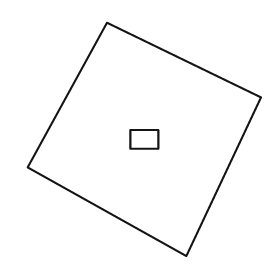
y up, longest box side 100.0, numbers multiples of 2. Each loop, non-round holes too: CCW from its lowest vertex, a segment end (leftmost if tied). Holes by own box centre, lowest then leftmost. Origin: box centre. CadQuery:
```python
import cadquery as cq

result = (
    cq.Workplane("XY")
    .moveTo(18.0, -50.0)
    .lineTo(50.0, 18.0)
    .lineTo(-16.0, 50.0)
    .lineTo(-50.0, -12.0)
    .close()
    .moveTo(-6.0, -4.0)
    .lineTo(6.0, -4.0)
    .lineTo(6.0, 4.0)
    .lineTo(-6.0, 4.0)
    .close()
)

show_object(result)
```